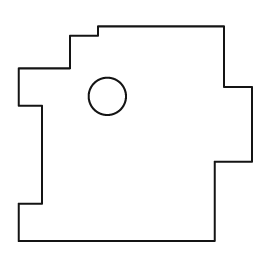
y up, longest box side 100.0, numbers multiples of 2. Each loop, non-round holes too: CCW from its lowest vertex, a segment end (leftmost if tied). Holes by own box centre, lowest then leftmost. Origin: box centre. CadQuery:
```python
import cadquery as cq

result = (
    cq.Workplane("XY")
    .moveTo(-50.0, -46.0)
    .lineTo(34.0, -46.0)
    .lineTo(34.0, -12.0)
    .lineTo(50.0, -12.0)
    .lineTo(50.0, 20.0)
    .lineTo(38.0, 20.0)
    .lineTo(38.0, 46.0)
    .lineTo(-16.0, 46.0)
    .lineTo(-16.0, 42.0)
    .lineTo(-28.0, 42.0)
    .lineTo(-28.0, 28.0)
    .lineTo(-50.0, 28.0)
    .lineTo(-50.0, 12.0)
    .lineTo(-40.0, 12.0)
    .lineTo(-40.0, -30.0)
    .lineTo(-50.0, -30.0)
    .close()
    .moveTo(-12.0, 16.0)
    .circle(8.0)
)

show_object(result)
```